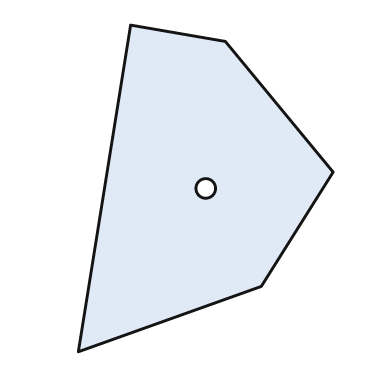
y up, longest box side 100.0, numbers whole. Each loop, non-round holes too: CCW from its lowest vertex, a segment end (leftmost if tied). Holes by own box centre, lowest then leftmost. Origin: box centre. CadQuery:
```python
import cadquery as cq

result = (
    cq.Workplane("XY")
    .moveTo(-39.0, -50.0)
    .lineTo(17.0, -30.0)
    .lineTo(39.0, 5.0)
    .lineTo(6.0, 45.0)
    .lineTo(-23.0, 50.0)
    .close()
    .moveTo(0.0, 0.0)
    .circle(3.0)
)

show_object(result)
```